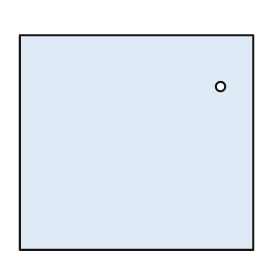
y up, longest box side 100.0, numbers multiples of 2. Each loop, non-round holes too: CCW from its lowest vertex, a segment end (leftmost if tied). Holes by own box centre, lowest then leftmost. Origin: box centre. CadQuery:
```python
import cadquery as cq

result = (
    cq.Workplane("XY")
    .moveTo(-50.0, -46.0)
    .lineTo(50.0, -46.0)
    .lineTo(50.0, 46.0)
    .lineTo(-50.0, 46.0)
    .close()
    .moveTo(36.0, 24.0)
    .circle(2.0)
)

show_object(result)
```